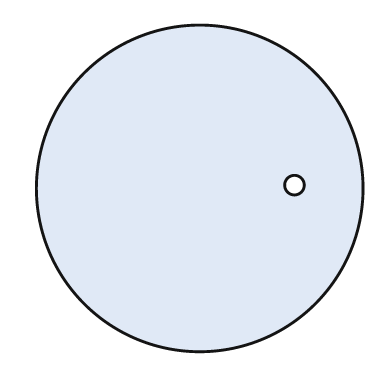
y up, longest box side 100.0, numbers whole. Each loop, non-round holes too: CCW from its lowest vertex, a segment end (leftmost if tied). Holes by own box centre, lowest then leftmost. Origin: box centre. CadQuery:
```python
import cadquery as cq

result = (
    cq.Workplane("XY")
    .moveTo(0.0, 0.0)
    .circle(50.0)
    .moveTo(29.0, 1.0)
    .circle(3.0)
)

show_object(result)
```